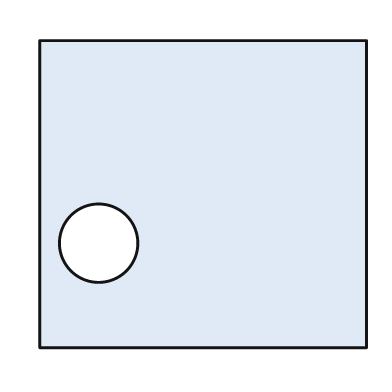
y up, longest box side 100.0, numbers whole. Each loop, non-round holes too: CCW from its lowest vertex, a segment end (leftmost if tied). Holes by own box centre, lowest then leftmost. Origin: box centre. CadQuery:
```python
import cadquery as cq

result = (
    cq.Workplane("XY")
    .moveTo(-50.0, -47.0)
    .lineTo(50.0, -47.0)
    .lineTo(50.0, 47.0)
    .lineTo(-50.0, 47.0)
    .close()
    .moveTo(-32.0, -15.0)
    .circle(12.0)
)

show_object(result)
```